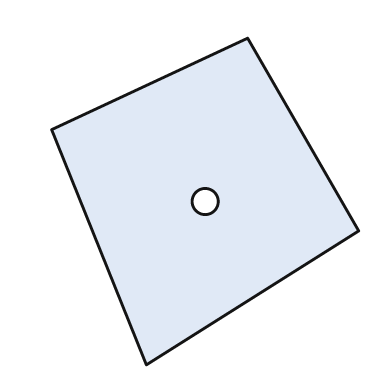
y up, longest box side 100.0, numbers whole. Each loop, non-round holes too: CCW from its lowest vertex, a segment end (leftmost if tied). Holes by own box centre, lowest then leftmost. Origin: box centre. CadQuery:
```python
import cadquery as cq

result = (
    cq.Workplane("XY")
    .moveTo(-18.0, -50.0)
    .lineTo(47.0, -9.0)
    .lineTo(13.0, 50.0)
    .lineTo(-47.0, 22.0)
    .close()
    .moveTo(0.0, 0.0)
    .circle(4.0)
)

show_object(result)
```